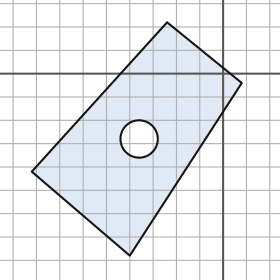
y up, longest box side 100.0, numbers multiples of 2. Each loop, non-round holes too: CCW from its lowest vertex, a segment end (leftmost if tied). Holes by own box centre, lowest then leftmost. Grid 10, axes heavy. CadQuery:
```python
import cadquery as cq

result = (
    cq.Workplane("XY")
    .moveTo(-40.0, -78.0)
    .lineTo(8.0, -4.0)
    .lineTo(-24.0, 22.0)
    .lineTo(-82.0, -42.0)
    .close()
    .moveTo(-36.0, -28.0)
    .circle(8.0)
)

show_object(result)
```